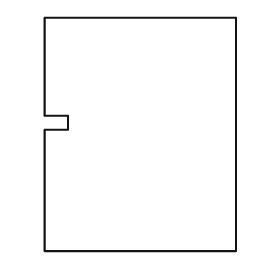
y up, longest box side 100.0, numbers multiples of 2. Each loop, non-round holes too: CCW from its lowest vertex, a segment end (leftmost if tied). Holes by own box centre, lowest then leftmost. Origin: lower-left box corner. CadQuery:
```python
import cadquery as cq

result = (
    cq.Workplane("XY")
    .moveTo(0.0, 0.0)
    .lineTo(82.0, 0.0)
    .lineTo(82.0, 100.0)
    .lineTo(0.0, 100.0)
    .lineTo(0.0, 58.0)
    .lineTo(10.0, 58.0)
    .lineTo(10.0, 52.0)
    .lineTo(0.0, 52.0)
    .close()
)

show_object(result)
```